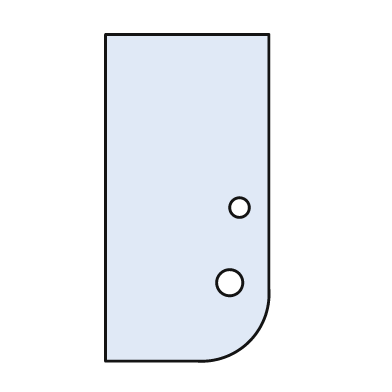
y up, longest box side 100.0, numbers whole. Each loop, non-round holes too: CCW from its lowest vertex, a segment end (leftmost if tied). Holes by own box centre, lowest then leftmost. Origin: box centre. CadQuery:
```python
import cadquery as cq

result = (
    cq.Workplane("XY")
    .moveTo(-25.0, -50.0)
    .lineTo(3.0, -50.0)
    .threePointArc((19.0, -44.0), (25.0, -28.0))
    .lineTo(25.0, 50.0)
    .lineTo(-25.0, 50.0)
    .close()
    .moveTo(13.0, -26.0)
    .circle(4.0)
    .moveTo(16.0, -3.0)
    .circle(3.0)
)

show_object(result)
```